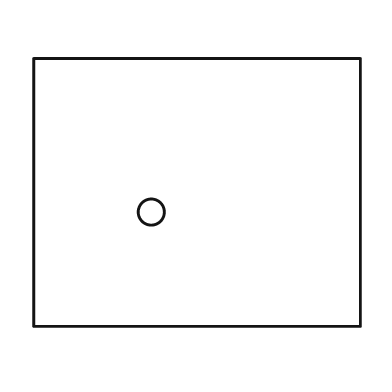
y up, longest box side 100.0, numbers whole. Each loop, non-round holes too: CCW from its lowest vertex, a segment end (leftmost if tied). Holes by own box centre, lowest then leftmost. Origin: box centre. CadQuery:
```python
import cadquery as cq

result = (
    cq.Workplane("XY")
    .moveTo(-50.0, -41.0)
    .lineTo(50.0, -41.0)
    .lineTo(50.0, 41.0)
    .lineTo(-50.0, 41.0)
    .close()
    .moveTo(-14.0, -6.0)
    .circle(4.0)
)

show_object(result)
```